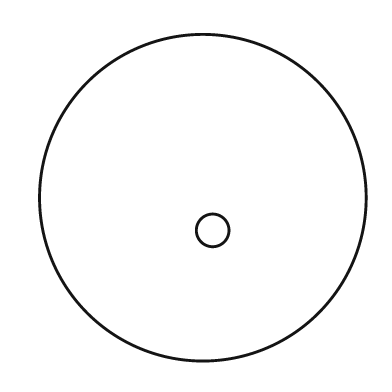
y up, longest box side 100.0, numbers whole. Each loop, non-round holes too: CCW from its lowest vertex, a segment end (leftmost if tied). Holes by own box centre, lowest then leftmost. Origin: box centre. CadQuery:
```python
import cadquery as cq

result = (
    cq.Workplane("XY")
    .moveTo(0.0, 0.0)
    .circle(50.0)
    .moveTo(3.0, -10.0)
    .circle(5.0)
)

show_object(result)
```